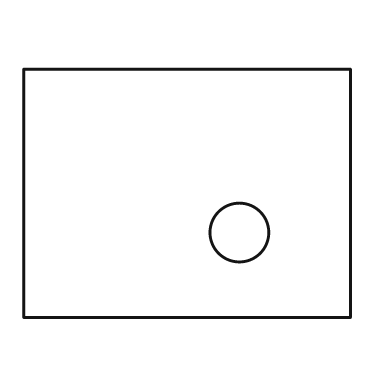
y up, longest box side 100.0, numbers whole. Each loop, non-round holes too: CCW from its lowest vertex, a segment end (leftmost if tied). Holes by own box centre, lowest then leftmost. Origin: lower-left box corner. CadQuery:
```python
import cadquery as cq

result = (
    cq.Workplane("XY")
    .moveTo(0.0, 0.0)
    .lineTo(100.0, 0.0)
    .lineTo(100.0, 76.0)
    .lineTo(0.0, 76.0)
    .close()
    .moveTo(66.0, 26.0)
    .circle(9.0)
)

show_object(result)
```